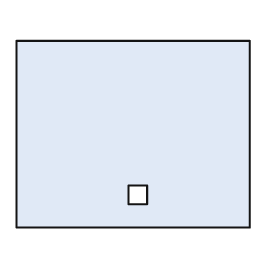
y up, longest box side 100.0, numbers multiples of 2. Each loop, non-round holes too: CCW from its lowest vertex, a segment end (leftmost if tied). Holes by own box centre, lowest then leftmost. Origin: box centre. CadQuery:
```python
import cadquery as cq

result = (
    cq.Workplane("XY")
    .moveTo(-50.0, -40.0)
    .lineTo(50.0, -40.0)
    .lineTo(50.0, 40.0)
    .lineTo(-50.0, 40.0)
    .close()
    .moveTo(-2.0, -30.0)
    .lineTo(6.0, -30.0)
    .lineTo(6.0, -22.0)
    .lineTo(-2.0, -22.0)
    .close()
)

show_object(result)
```